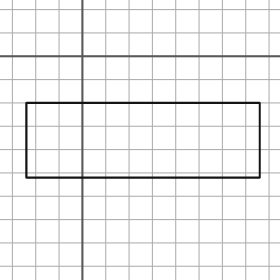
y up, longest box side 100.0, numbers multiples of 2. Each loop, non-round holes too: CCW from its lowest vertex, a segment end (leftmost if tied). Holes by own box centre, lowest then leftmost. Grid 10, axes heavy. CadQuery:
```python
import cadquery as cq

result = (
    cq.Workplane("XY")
    .moveTo(-24.0, -52.0)
    .lineTo(76.0, -52.0)
    .lineTo(76.0, -20.0)
    .lineTo(-24.0, -20.0)
    .close()
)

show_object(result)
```